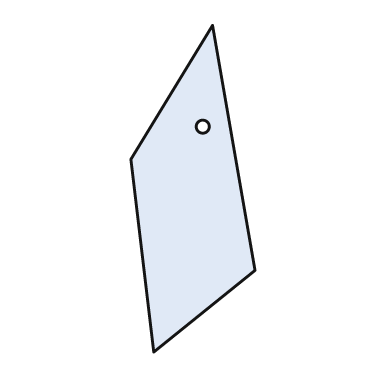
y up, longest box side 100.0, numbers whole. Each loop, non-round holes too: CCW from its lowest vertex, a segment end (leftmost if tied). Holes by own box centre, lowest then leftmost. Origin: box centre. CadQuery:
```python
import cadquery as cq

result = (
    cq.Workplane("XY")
    .moveTo(-12.0, -50.0)
    .lineTo(19.0, -25.0)
    .lineTo(6.0, 50.0)
    .lineTo(-19.0, 9.0)
    .close()
    .moveTo(3.0, 19.0)
    .circle(2.0)
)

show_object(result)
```